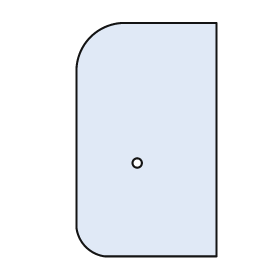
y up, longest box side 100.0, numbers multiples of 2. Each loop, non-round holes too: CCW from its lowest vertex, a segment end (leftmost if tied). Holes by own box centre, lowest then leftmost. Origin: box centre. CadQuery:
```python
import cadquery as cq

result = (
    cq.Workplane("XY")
    .moveTo(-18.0, -50.0)
    .lineTo(30.0, -50.0)
    .lineTo(30.0, 50.0)
    .lineTo(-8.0, 50.0)
    .threePointArc((-24.0, 44.0), (-30.0, 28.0))
    .lineTo(-30.0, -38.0)
    .threePointArc((-26.0, -46.0), (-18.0, -50.0))
    .close()
    .moveTo(-4.0, -10.0)
    .circle(2.0)
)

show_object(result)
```